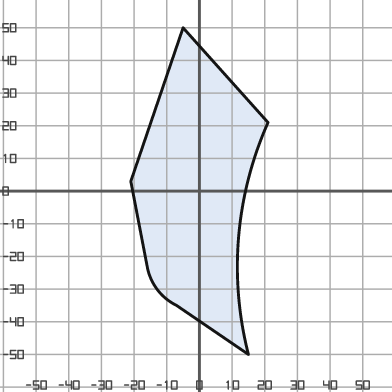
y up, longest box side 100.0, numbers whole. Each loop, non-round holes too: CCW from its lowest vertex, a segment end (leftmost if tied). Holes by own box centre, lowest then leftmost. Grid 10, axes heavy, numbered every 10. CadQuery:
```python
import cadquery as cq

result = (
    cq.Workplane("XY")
    .moveTo(15.0, -50.0)
    .threePointArc((12.0, -14.0), (21.0, 21.0))
    .lineTo(-5.0, 50.0)
    .lineTo(-21.0, 3.0)
    .lineTo(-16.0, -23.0)
    .threePointArc((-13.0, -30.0), (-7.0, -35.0))
    .close()
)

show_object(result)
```